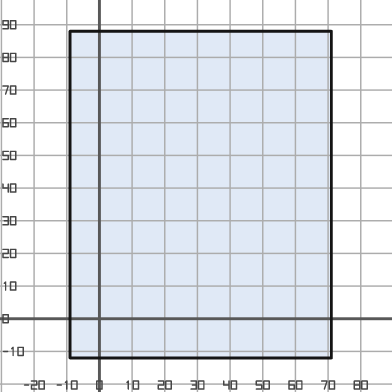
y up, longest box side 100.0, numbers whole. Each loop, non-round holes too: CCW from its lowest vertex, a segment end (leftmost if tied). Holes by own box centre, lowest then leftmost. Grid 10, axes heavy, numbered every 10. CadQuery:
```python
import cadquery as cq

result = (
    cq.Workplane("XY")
    .moveTo(-9.0, -12.0)
    .lineTo(71.0, -12.0)
    .lineTo(71.0, 88.0)
    .lineTo(-9.0, 88.0)
    .close()
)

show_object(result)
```